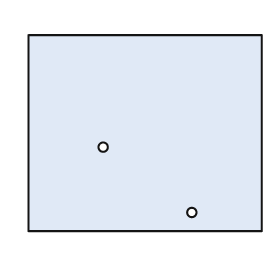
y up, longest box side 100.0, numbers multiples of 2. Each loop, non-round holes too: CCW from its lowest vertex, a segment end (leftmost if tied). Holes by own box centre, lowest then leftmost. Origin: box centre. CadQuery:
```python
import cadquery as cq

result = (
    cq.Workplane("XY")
    .moveTo(-50.0, -42.0)
    .lineTo(50.0, -42.0)
    .lineTo(50.0, 42.0)
    .lineTo(-50.0, 42.0)
    .close()
    .moveTo(20.0, -34.0)
    .circle(2.0)
    .moveTo(-18.0, -6.0)
    .circle(2.0)
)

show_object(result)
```